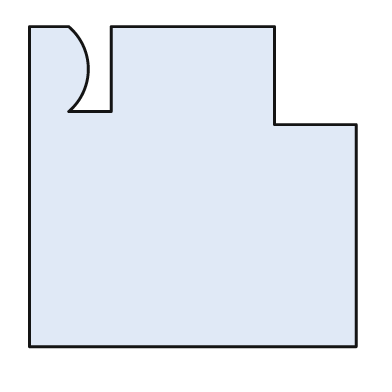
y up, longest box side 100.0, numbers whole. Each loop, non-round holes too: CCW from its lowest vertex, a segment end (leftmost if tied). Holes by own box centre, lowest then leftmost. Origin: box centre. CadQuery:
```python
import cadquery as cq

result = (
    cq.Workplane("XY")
    .moveTo(-50.0, -49.0)
    .lineTo(50.0, -49.0)
    .lineTo(50.0, 19.0)
    .lineTo(25.0, 19.0)
    .lineTo(25.0, 49.0)
    .lineTo(-25.0, 49.0)
    .lineTo(-25.0, 23.0)
    .lineTo(-38.0, 23.0)
    .threePointArc((-32.0, 36.0), (-38.0, 49.0))
    .lineTo(-50.0, 49.0)
    .close()
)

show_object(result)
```